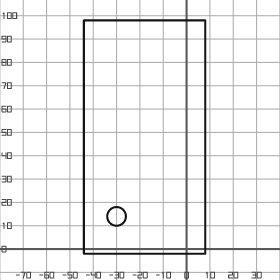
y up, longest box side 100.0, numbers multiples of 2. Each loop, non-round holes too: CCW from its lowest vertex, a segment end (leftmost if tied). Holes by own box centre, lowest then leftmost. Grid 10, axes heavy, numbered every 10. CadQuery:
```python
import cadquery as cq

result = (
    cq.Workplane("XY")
    .moveTo(-44.0, -2.0)
    .lineTo(8.0, -2.0)
    .lineTo(8.0, 98.0)
    .lineTo(-44.0, 98.0)
    .close()
    .moveTo(-30.0, 14.0)
    .circle(4.0)
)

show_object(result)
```